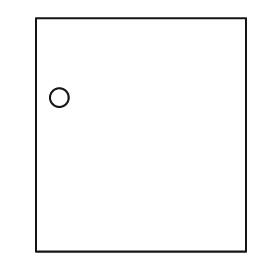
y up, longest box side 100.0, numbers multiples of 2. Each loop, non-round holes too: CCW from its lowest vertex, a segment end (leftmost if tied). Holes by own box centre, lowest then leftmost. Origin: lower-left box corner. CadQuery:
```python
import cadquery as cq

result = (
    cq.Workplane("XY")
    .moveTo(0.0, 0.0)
    .lineTo(90.0, 0.0)
    .lineTo(90.0, 100.0)
    .lineTo(0.0, 100.0)
    .close()
    .moveTo(10.0, 66.0)
    .circle(4.0)
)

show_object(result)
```